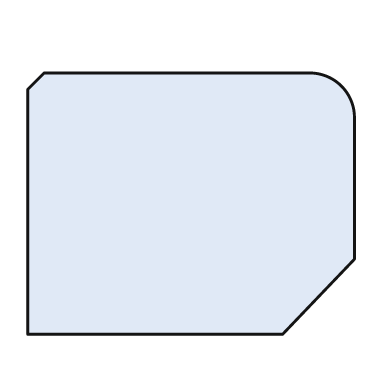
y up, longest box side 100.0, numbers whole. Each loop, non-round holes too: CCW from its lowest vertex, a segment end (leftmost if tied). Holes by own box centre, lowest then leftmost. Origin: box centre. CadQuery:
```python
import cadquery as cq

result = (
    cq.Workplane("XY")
    .moveTo(-50.0, -40.0)
    .lineTo(28.0, -40.0)
    .lineTo(50.0, -17.0)
    .lineTo(50.0, 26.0)
    .threePointArc((46.0, 36.0), (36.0, 40.0))
    .lineTo(-45.0, 40.0)
    .lineTo(-50.0, 35.0)
    .close()
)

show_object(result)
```